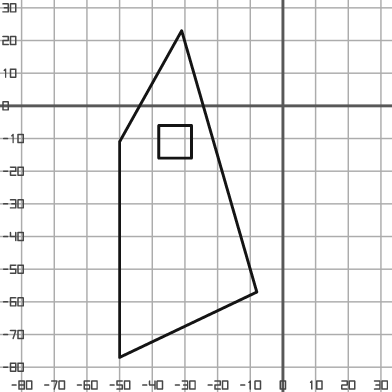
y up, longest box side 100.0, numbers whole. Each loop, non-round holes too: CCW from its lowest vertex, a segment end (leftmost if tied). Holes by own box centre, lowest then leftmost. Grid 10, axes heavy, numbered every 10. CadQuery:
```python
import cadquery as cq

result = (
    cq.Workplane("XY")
    .moveTo(-50.0, -77.0)
    .lineTo(-8.0, -57.0)
    .lineTo(-31.0, 23.0)
    .lineTo(-50.0, -11.0)
    .close()
    .moveTo(-38.0, -16.0)
    .lineTo(-28.0, -16.0)
    .lineTo(-28.0, -6.0)
    .lineTo(-38.0, -6.0)
    .close()
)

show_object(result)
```